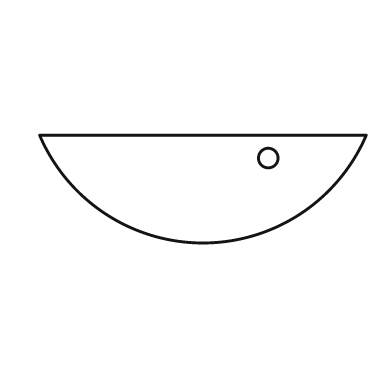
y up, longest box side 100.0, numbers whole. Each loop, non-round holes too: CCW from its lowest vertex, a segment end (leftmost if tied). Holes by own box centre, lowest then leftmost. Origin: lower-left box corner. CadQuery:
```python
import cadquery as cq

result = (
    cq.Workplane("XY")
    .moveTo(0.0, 33.0)
    .threePointArc((50.0, 0.0), (100.0, 33.0))
    .close()
    .moveTo(70.0, 26.0)
    .circle(3.0)
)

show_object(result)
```